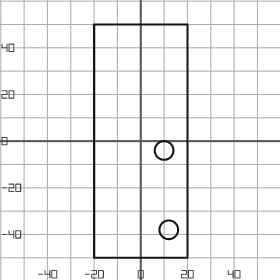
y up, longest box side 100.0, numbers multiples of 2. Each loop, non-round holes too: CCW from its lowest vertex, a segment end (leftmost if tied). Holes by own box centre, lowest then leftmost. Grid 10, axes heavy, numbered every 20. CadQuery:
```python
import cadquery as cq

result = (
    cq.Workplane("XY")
    .moveTo(-20.0, -50.0)
    .lineTo(20.0, -50.0)
    .lineTo(20.0, 50.0)
    .lineTo(-20.0, 50.0)
    .close()
    .moveTo(12.0, -38.0)
    .circle(4.0)
    .moveTo(10.0, -4.0)
    .circle(4.0)
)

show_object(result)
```